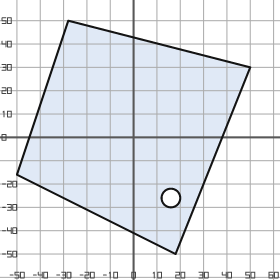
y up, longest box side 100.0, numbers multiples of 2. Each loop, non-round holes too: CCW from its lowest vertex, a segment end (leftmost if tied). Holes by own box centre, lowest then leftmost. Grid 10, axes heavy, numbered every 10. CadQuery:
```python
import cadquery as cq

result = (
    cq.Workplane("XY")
    .moveTo(18.0, -50.0)
    .lineTo(50.0, 30.0)
    .lineTo(-28.0, 50.0)
    .lineTo(-50.0, -16.0)
    .close()
    .moveTo(16.0, -26.0)
    .circle(4.0)
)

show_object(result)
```